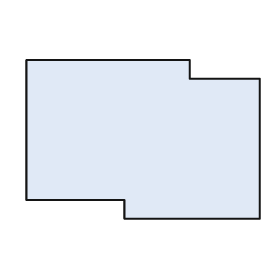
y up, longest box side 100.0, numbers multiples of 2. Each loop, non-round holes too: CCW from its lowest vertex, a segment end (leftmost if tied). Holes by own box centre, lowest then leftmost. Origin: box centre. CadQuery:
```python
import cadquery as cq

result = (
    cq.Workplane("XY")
    .moveTo(-8.0, -34.0)
    .lineTo(50.0, -34.0)
    .lineTo(50.0, 26.0)
    .lineTo(20.0, 26.0)
    .lineTo(20.0, 34.0)
    .lineTo(-50.0, 34.0)
    .lineTo(-50.0, -26.0)
    .lineTo(-8.0, -26.0)
    .close()
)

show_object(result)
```